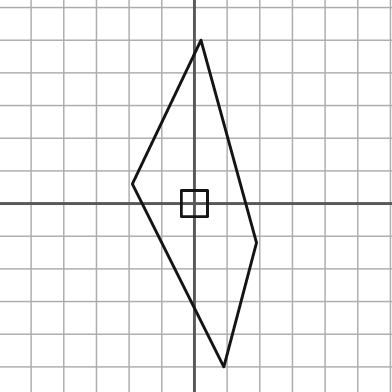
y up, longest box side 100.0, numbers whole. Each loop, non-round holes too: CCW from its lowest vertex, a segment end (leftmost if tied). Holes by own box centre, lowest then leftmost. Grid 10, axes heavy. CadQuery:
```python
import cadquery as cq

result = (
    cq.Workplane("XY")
    .moveTo(9.0, -50.0)
    .lineTo(19.0, -12.0)
    .lineTo(2.0, 50.0)
    .lineTo(-19.0, 6.0)
    .close()
    .moveTo(-4.0, -4.0)
    .lineTo(4.0, -4.0)
    .lineTo(4.0, 4.0)
    .lineTo(-4.0, 4.0)
    .close()
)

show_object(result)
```